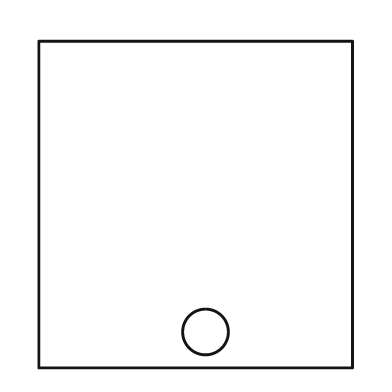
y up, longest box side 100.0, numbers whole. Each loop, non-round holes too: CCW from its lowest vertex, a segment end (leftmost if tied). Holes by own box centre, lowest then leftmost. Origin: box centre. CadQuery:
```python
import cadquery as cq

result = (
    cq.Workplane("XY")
    .moveTo(-48.0, -50.0)
    .lineTo(48.0, -50.0)
    .lineTo(48.0, 50.0)
    .lineTo(-48.0, 50.0)
    .close()
    .moveTo(3.0, -39.0)
    .circle(7.0)
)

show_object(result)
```